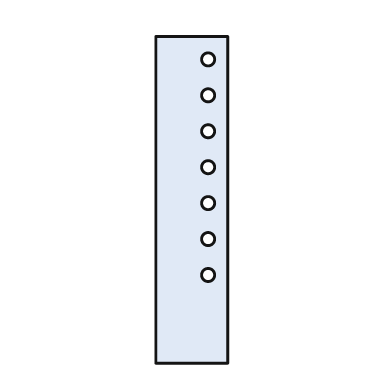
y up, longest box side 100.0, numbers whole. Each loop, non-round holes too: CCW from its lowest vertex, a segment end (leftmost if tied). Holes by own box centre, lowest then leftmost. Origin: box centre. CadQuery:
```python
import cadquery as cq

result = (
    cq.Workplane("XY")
    .moveTo(-11.0, -50.0)
    .lineTo(11.0, -50.0)
    .lineTo(11.0, 50.0)
    .lineTo(-11.0, 50.0)
    .close()
    .moveTo(5.0, -23.0)
    .circle(2.0)
    .moveTo(5.0, -12.0)
    .circle(2.0)
    .moveTo(5.0, -1.0)
    .circle(2.0)
    .moveTo(5.0, 10.0)
    .circle(2.0)
    .moveTo(5.0, 21.0)
    .circle(2.0)
    .moveTo(5.0, 32.0)
    .circle(2.0)
    .moveTo(5.0, 43.0)
    .circle(2.0)
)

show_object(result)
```